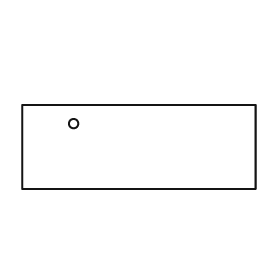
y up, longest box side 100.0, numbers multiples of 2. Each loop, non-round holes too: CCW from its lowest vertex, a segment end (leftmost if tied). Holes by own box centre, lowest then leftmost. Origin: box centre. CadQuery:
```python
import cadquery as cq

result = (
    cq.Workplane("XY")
    .moveTo(-50.0, -18.0)
    .lineTo(50.0, -18.0)
    .lineTo(50.0, 18.0)
    .lineTo(-50.0, 18.0)
    .close()
    .moveTo(-28.0, 10.0)
    .circle(2.0)
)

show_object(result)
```